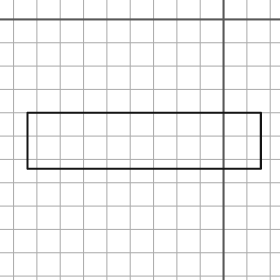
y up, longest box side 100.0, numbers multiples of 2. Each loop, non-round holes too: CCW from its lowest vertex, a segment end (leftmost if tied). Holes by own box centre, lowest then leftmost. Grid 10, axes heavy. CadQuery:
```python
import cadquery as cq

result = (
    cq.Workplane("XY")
    .moveTo(-84.0, -64.0)
    .lineTo(16.0, -64.0)
    .lineTo(16.0, -40.0)
    .lineTo(-84.0, -40.0)
    .close()
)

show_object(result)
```